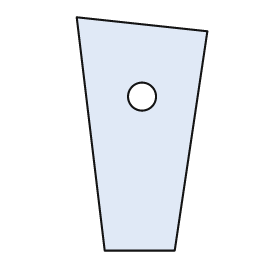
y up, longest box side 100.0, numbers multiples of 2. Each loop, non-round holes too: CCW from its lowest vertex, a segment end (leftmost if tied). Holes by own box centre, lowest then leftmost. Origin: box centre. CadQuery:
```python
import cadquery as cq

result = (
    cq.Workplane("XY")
    .moveTo(-16.0, -50.0)
    .lineTo(14.0, -50.0)
    .lineTo(28.0, 44.0)
    .lineTo(-28.0, 50.0)
    .close()
    .moveTo(0.0, 16.0)
    .circle(6.0)
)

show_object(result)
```